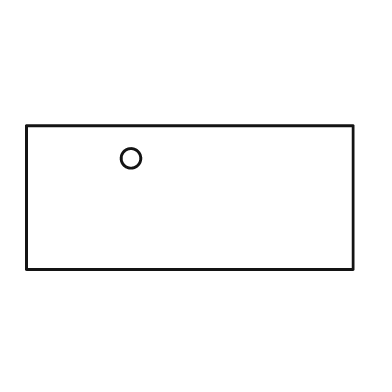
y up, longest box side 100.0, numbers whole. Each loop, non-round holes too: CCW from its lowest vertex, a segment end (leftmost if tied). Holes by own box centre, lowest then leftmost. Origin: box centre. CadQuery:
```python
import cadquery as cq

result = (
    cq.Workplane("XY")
    .moveTo(-50.0, -22.0)
    .lineTo(50.0, -22.0)
    .lineTo(50.0, 22.0)
    .lineTo(-50.0, 22.0)
    .close()
    .moveTo(-18.0, 12.0)
    .circle(3.0)
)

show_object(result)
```